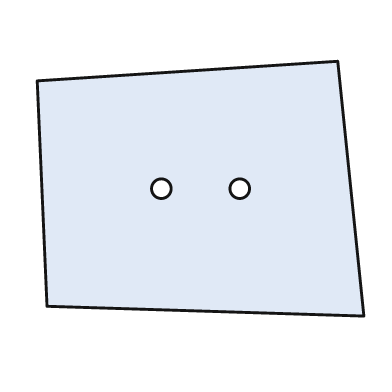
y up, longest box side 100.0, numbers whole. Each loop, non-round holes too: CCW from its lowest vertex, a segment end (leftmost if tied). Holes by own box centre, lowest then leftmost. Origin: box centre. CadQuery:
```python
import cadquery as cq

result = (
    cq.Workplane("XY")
    .moveTo(50.0, -39.0)
    .lineTo(42.0, 39.0)
    .lineTo(-50.0, 33.0)
    .lineTo(-47.0, -36.0)
    .close()
    .moveTo(-12.0, 0.0)
    .circle(3.0)
    .moveTo(12.0, 0.0)
    .circle(3.0)
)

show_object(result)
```